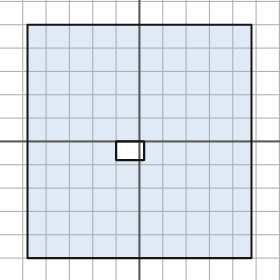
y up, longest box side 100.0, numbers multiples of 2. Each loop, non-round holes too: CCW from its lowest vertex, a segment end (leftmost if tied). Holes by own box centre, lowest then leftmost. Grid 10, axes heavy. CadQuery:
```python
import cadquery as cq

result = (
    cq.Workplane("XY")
    .moveTo(-48.0, -50.0)
    .lineTo(48.0, -50.0)
    .lineTo(48.0, 50.0)
    .lineTo(-48.0, 50.0)
    .close()
    .moveTo(-10.0, -8.0)
    .lineTo(2.0, -8.0)
    .lineTo(2.0, 0.0)
    .lineTo(-10.0, 0.0)
    .close()
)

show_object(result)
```